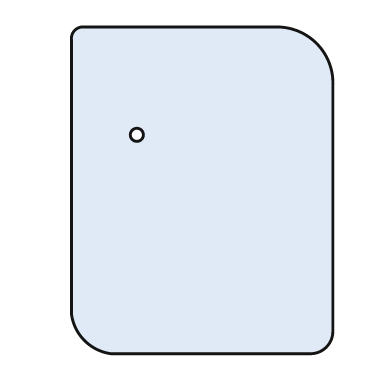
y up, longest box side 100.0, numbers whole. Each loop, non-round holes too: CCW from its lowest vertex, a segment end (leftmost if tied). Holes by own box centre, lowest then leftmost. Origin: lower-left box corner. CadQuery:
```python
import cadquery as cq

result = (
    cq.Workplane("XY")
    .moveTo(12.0, 0.0)
    .lineTo(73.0, 0.0)
    .threePointArc((78.0, 2.0), (80.0, 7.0))
    .lineTo(80.0, 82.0)
    .threePointArc((75.0, 95.0), (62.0, 100.0))
    .lineTo(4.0, 100.0)
    .threePointArc((1.0, 99.0), (0.0, 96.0))
    .lineTo(0.0, 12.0)
    .threePointArc((4.0, 4.0), (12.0, 0.0))
    .close()
    .moveTo(20.0, 67.0)
    .circle(2.0)
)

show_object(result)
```